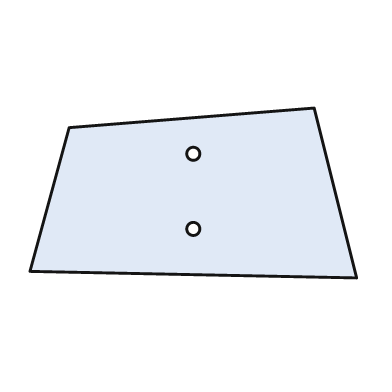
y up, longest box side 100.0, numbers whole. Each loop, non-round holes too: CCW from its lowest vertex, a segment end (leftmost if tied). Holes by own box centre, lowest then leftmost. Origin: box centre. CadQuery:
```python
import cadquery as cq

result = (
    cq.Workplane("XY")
    .moveTo(50.0, -26.0)
    .lineTo(37.0, 26.0)
    .lineTo(-38.0, 20.0)
    .lineTo(-50.0, -24.0)
    .close()
    .moveTo(0.0, -11.0)
    .circle(2.0)
    .moveTo(0.0, 12.0)
    .circle(2.0)
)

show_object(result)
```